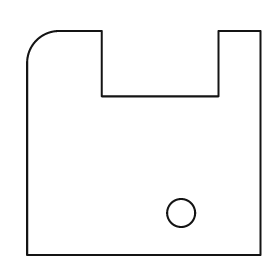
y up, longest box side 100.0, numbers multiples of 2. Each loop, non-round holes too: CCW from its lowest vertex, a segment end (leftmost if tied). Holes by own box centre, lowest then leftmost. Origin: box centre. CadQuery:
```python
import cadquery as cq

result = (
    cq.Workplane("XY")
    .moveTo(-50.0, -48.0)
    .lineTo(50.0, -48.0)
    .lineTo(50.0, 48.0)
    .lineTo(32.0, 48.0)
    .lineTo(32.0, 20.0)
    .lineTo(-18.0, 20.0)
    .lineTo(-18.0, 48.0)
    .lineTo(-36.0, 48.0)
    .threePointArc((-46.0, 44.0), (-50.0, 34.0))
    .close()
    .moveTo(16.0, -30.0)
    .circle(6.0)
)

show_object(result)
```